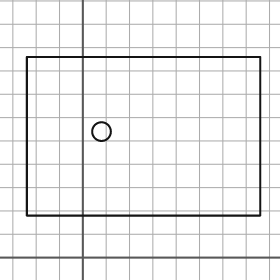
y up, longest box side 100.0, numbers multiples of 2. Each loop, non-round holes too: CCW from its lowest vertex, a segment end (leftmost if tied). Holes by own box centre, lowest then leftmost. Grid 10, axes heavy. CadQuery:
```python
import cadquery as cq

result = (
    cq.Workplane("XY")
    .moveTo(-24.0, 18.0)
    .lineTo(76.0, 18.0)
    .lineTo(76.0, 86.0)
    .lineTo(-24.0, 86.0)
    .close()
    .moveTo(8.0, 54.0)
    .circle(4.0)
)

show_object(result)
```